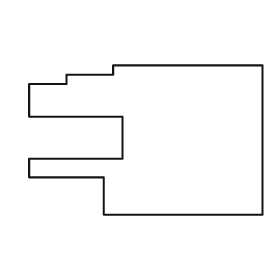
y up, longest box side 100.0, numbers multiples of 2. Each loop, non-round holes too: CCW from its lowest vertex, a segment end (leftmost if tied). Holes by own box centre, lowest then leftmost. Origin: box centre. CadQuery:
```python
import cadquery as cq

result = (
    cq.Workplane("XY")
    .moveTo(-18.0, -32.0)
    .lineTo(50.0, -32.0)
    .lineTo(50.0, 32.0)
    .lineTo(-14.0, 32.0)
    .lineTo(-14.0, 28.0)
    .lineTo(-34.0, 28.0)
    .lineTo(-34.0, 24.0)
    .lineTo(-50.0, 24.0)
    .lineTo(-50.0, 10.0)
    .lineTo(-10.0, 10.0)
    .lineTo(-10.0, -8.0)
    .lineTo(-50.0, -8.0)
    .lineTo(-50.0, -16.0)
    .lineTo(-18.0, -16.0)
    .close()
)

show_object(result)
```